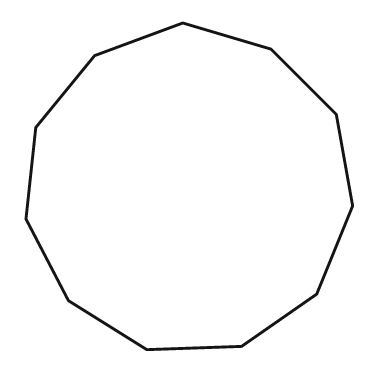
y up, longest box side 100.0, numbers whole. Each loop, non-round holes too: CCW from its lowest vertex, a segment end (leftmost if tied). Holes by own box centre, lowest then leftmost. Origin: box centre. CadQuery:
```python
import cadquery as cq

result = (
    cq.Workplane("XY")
    .moveTo(-13.0, -50.0)
    .lineTo(16.0, -49.0)
    .lineTo(39.0, -33.0)
    .lineTo(50.0, -6.0)
    .lineTo(45.0, 22.0)
    .lineTo(25.0, 42.0)
    .lineTo(-2.0, 50.0)
    .lineTo(-29.0, 40.0)
    .lineTo(-47.0, 18.0)
    .lineTo(-50.0, -10.0)
    .lineTo(-37.0, -35.0)
    .close()
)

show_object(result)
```